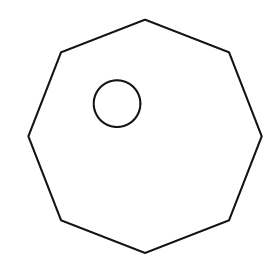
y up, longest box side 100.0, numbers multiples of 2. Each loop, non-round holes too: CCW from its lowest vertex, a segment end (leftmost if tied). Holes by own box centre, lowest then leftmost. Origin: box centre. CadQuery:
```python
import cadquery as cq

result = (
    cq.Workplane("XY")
    .moveTo(0.0, -50.0)
    .lineTo(36.0, -36.0)
    .lineTo(50.0, 0.0)
    .lineTo(36.0, 36.0)
    .lineTo(0.0, 50.0)
    .lineTo(-36.0, 36.0)
    .lineTo(-50.0, 0.0)
    .lineTo(-36.0, -36.0)
    .close()
    .moveTo(-12.0, 14.0)
    .circle(10.0)
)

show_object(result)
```